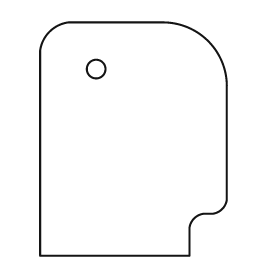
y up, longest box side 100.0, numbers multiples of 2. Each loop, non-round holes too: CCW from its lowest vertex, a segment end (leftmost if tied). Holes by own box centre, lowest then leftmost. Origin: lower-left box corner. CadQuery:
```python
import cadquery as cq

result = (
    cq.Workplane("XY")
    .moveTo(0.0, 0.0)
    .lineTo(64.0, 0.0)
    .lineTo(64.0, 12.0)
    .threePointArc((66.0, 16.0), (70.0, 18.0))
    .lineTo(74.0, 18.0)
    .threePointArc((78.0, 20.0), (80.0, 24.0))
    .lineTo(80.0, 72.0)
    .threePointArc((72.0, 92.0), (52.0, 100.0))
    .lineTo(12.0, 100.0)
    .threePointArc((4.0, 96.0), (0.0, 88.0))
    .close()
    .moveTo(24.0, 80.0)
    .circle(4.0)
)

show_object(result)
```